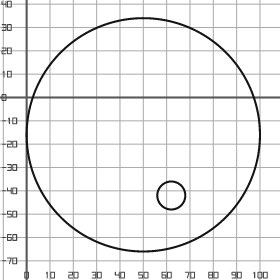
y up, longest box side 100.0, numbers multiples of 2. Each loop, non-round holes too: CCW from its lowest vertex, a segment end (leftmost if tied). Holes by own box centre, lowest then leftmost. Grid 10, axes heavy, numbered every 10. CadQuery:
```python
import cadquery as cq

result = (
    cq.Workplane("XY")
    .moveTo(50.0, -16.0)
    .circle(50.0)
    .moveTo(62.0, -42.0)
    .circle(6.0)
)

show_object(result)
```